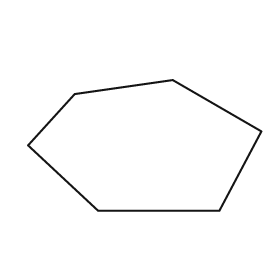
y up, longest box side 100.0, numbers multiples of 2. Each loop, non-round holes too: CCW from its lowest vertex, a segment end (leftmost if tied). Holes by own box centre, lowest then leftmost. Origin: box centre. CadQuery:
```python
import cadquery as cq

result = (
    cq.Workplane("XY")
    .moveTo(-20.0, -28.0)
    .lineTo(32.0, -28.0)
    .lineTo(50.0, 6.0)
    .lineTo(12.0, 28.0)
    .lineTo(-30.0, 22.0)
    .lineTo(-50.0, 0.0)
    .close()
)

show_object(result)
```